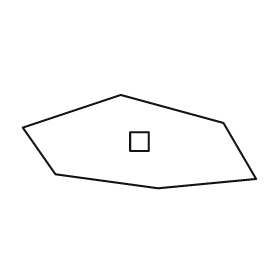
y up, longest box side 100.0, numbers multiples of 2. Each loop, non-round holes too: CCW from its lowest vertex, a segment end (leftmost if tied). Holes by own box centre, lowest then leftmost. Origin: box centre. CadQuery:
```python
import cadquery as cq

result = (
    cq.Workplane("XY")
    .moveTo(8.0, -20.0)
    .lineTo(50.0, -16.0)
    .lineTo(36.0, 8.0)
    .lineTo(-8.0, 20.0)
    .lineTo(-50.0, 6.0)
    .lineTo(-36.0, -14.0)
    .close()
    .moveTo(-4.0, -4.0)
    .lineTo(4.0, -4.0)
    .lineTo(4.0, 4.0)
    .lineTo(-4.0, 4.0)
    .close()
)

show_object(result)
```